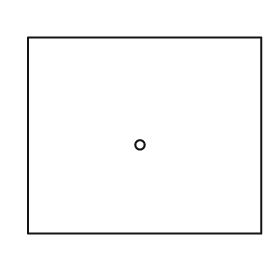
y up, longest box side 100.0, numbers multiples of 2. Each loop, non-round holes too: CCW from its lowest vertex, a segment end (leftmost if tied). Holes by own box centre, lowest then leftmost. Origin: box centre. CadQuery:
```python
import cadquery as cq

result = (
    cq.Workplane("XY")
    .moveTo(-50.0, -42.0)
    .lineTo(50.0, -42.0)
    .lineTo(50.0, 42.0)
    .lineTo(-50.0, 42.0)
    .close()
    .moveTo(-2.0, -4.0)
    .circle(2.0)
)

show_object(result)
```